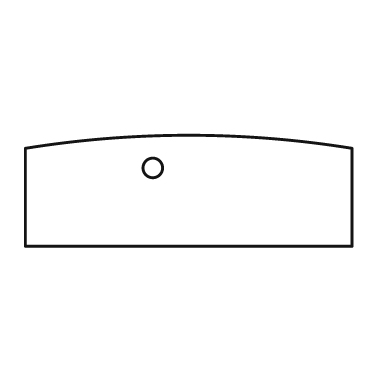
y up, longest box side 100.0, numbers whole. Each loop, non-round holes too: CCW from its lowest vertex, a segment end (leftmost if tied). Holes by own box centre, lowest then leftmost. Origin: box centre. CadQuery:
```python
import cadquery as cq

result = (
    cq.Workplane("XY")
    .moveTo(-50.0, -17.0)
    .lineTo(50.0, -17.0)
    .lineTo(50.0, 13.0)
    .threePointArc((0.0, 17.0), (-50.0, 13.0))
    .close()
    .moveTo(-11.0, 7.0)
    .circle(3.0)
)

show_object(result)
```